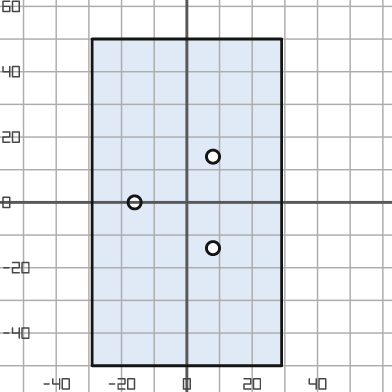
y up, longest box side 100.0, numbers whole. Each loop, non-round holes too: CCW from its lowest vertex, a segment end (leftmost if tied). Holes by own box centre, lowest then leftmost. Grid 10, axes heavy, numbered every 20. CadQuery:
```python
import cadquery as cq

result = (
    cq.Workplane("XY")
    .moveTo(-29.0, -50.0)
    .lineTo(29.0, -50.0)
    .lineTo(29.0, 50.0)
    .lineTo(-29.0, 50.0)
    .close()
    .moveTo(8.0, -14.0)
    .circle(2.0)
    .moveTo(-16.0, 0.0)
    .circle(2.0)
    .moveTo(8.0, 14.0)
    .circle(2.0)
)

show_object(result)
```